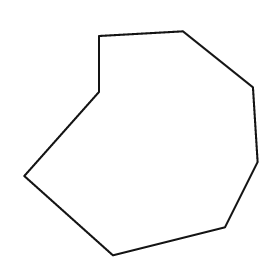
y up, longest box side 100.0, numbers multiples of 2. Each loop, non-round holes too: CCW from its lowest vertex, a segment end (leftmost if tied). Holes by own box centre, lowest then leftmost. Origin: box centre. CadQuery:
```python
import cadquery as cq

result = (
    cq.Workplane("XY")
    .moveTo(-12.0, -48.0)
    .lineTo(36.0, -36.0)
    .lineTo(50.0, -8.0)
    .lineTo(48.0, 24.0)
    .lineTo(18.0, 48.0)
    .lineTo(-18.0, 46.0)
    .lineTo(-18.0, 22.0)
    .lineTo(-50.0, -14.0)
    .close()
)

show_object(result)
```